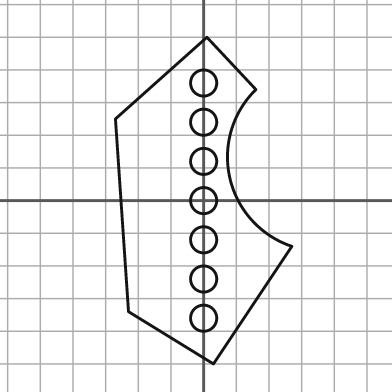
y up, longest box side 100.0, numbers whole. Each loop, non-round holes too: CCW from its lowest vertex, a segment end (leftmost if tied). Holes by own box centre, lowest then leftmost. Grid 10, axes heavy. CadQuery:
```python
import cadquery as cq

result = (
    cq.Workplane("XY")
    .moveTo(3.0, -50.0)
    .lineTo(27.0, -14.0)
    .threePointArc((8.0, 7.0), (16.0, 34.0))
    .lineTo(1.0, 50.0)
    .lineTo(-27.0, 25.0)
    .lineTo(-23.0, -34.0)
    .close()
    .moveTo(0.0, -36.0)
    .circle(4.0)
    .moveTo(0.0, -24.0)
    .circle(4.0)
    .moveTo(0.0, -12.0)
    .circle(4.0)
    .moveTo(0.0, 0.0)
    .circle(4.0)
    .moveTo(0.0, 12.0)
    .circle(4.0)
    .moveTo(0.0, 24.0)
    .circle(4.0)
    .moveTo(0.0, 36.0)
    .circle(4.0)
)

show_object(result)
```